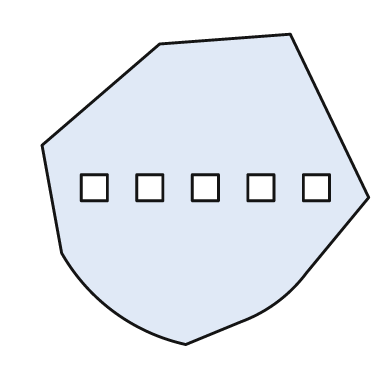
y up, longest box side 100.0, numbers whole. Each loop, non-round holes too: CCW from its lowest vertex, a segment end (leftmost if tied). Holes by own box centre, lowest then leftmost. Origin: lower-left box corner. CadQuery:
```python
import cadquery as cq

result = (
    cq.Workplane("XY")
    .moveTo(44.0, 0.0)
    .lineTo(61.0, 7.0)
    .threePointArc((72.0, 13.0), (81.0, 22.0))
    .lineTo(100.0, 45.0)
    .lineTo(76.0, 95.0)
    .lineTo(36.0, 92.0)
    .lineTo(0.0, 61.0)
    .lineTo(6.0, 28.0)
    .threePointArc((22.0, 10.0), (44.0, 0.0))
    .close()
    .moveTo(12.0, 44.0)
    .lineTo(20.0, 44.0)
    .lineTo(20.0, 52.0)
    .lineTo(12.0, 52.0)
    .close()
    .moveTo(29.0, 44.0)
    .lineTo(37.0, 44.0)
    .lineTo(37.0, 52.0)
    .lineTo(29.0, 52.0)
    .close()
    .moveTo(46.0, 44.0)
    .lineTo(54.0, 44.0)
    .lineTo(54.0, 52.0)
    .lineTo(46.0, 52.0)
    .close()
    .moveTo(63.0, 44.0)
    .lineTo(71.0, 44.0)
    .lineTo(71.0, 52.0)
    .lineTo(63.0, 52.0)
    .close()
    .moveTo(80.0, 44.0)
    .lineTo(88.0, 44.0)
    .lineTo(88.0, 52.0)
    .lineTo(80.0, 52.0)
    .close()
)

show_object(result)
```